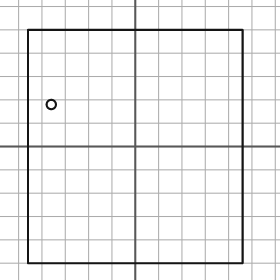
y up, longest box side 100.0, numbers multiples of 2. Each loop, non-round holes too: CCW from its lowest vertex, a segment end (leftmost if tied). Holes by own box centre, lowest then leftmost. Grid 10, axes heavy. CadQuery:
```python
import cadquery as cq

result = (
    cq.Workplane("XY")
    .moveTo(-46.0, -50.0)
    .lineTo(46.0, -50.0)
    .lineTo(46.0, 50.0)
    .lineTo(-46.0, 50.0)
    .close()
    .moveTo(-36.0, 18.0)
    .circle(2.0)
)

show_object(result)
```